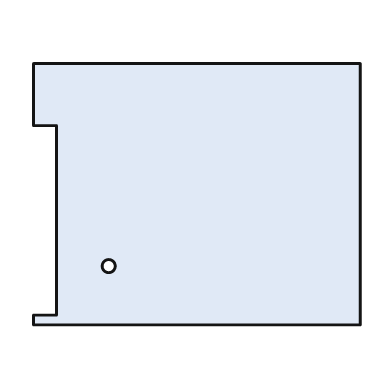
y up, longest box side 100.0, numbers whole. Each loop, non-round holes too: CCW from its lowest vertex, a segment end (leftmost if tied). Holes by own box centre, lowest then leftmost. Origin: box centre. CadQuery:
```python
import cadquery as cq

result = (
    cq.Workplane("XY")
    .moveTo(-50.0, -40.0)
    .lineTo(50.0, -40.0)
    .lineTo(50.0, 40.0)
    .lineTo(-50.0, 40.0)
    .lineTo(-50.0, 21.0)
    .lineTo(-43.0, 21.0)
    .lineTo(-43.0, -37.0)
    .lineTo(-50.0, -37.0)
    .close()
    .moveTo(-27.0, -22.0)
    .circle(2.0)
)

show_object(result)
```